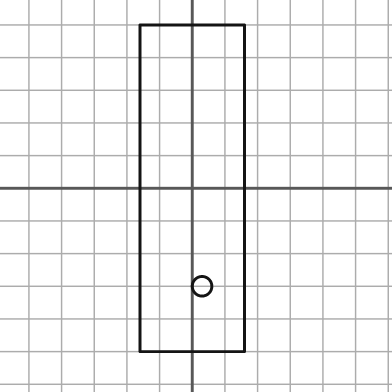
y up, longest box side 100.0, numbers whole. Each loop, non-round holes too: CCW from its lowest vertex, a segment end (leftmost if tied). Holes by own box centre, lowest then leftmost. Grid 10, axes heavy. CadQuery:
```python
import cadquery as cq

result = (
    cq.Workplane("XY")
    .moveTo(-16.0, -50.0)
    .lineTo(16.0, -50.0)
    .lineTo(16.0, 50.0)
    .lineTo(-16.0, 50.0)
    .close()
    .moveTo(3.0, -30.0)
    .circle(3.0)
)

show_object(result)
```